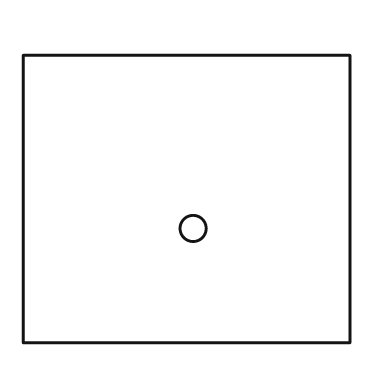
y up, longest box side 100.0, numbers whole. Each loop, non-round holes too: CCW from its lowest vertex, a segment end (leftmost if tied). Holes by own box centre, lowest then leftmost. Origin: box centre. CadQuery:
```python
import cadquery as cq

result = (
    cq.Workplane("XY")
    .moveTo(-50.0, -44.0)
    .lineTo(50.0, -44.0)
    .lineTo(50.0, 44.0)
    .lineTo(-50.0, 44.0)
    .close()
    .moveTo(2.0, -9.0)
    .circle(4.0)
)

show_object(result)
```